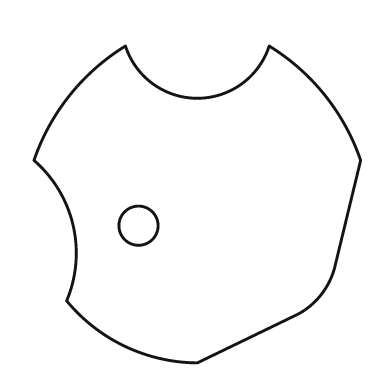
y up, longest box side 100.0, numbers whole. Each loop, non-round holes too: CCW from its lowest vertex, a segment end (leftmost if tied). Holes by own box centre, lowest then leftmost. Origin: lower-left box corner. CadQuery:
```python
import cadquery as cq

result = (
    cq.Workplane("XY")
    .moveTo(50.0, 0.0)
    .lineTo(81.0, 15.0)
    .threePointArc((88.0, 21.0), (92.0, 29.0))
    .lineTo(100.0, 62.0)
    .threePointArc((89.0, 82.0), (72.0, 97.0))
    .threePointArc((50.0, 81.0), (28.0, 97.0))
    .threePointArc((11.0, 82.0), (0.0, 62.0))
    .threePointArc((12.0, 42.0), (10.0, 19.0))
    .threePointArc((28.0, 5.0), (50.0, 0.0))
    .close()
    .moveTo(32.0, 42.0)
    .circle(6.0)
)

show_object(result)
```